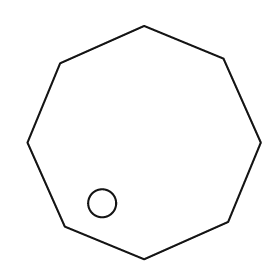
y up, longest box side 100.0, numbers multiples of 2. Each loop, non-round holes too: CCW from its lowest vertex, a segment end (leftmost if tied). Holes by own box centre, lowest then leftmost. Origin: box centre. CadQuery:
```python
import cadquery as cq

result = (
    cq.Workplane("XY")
    .moveTo(0.0, -50.0)
    .lineTo(36.0, -34.0)
    .lineTo(50.0, 0.0)
    .lineTo(34.0, 36.0)
    .lineTo(0.0, 50.0)
    .lineTo(-36.0, 34.0)
    .lineTo(-50.0, 0.0)
    .lineTo(-34.0, -36.0)
    .close()
    .moveTo(-18.0, -26.0)
    .circle(6.0)
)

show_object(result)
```